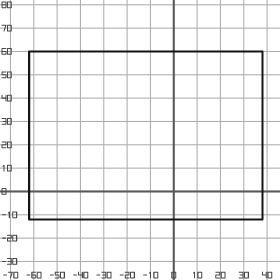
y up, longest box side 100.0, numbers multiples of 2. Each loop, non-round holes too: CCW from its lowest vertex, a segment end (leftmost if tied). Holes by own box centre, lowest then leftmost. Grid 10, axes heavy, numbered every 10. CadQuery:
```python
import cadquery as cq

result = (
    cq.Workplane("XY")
    .moveTo(-62.0, -12.0)
    .lineTo(38.0, -12.0)
    .lineTo(38.0, 60.0)
    .lineTo(-62.0, 60.0)
    .close()
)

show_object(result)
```